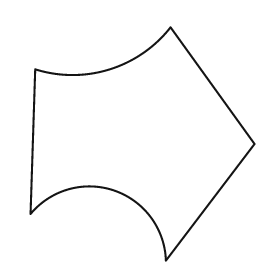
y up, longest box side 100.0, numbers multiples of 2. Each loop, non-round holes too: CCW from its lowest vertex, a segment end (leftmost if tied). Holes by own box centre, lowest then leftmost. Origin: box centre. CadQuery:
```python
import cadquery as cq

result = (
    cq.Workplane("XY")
    .moveTo(10.0, -50.0)
    .lineTo(48.0, 0.0)
    .lineTo(12.0, 50.0)
    .threePointArc((-14.0, 32.0), (-46.0, 32.0))
    .lineTo(-48.0, -30.0)
    .threePointArc((-12.0, -20.0), (10.0, -50.0))
    .close()
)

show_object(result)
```